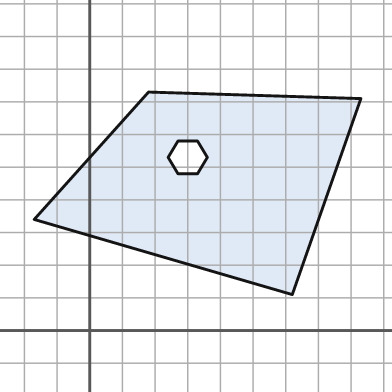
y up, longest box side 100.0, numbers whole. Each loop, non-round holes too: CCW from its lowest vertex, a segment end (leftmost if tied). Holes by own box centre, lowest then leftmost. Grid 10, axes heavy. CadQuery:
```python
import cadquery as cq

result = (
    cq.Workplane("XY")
    .moveTo(62.0, 11.0)
    .lineTo(83.0, 71.0)
    .lineTo(18.0, 73.0)
    .lineTo(-17.0, 34.0)
    .close()
    .moveTo(27.0, 48.0)
    .lineTo(33.0, 48.0)
    .lineTo(36.0, 53.0)
    .lineTo(33.0, 58.0)
    .lineTo(27.0, 58.0)
    .lineTo(24.0, 53.0)
    .close()
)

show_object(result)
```